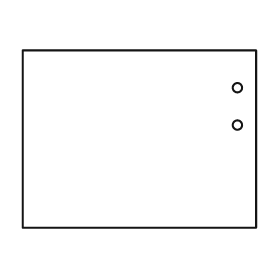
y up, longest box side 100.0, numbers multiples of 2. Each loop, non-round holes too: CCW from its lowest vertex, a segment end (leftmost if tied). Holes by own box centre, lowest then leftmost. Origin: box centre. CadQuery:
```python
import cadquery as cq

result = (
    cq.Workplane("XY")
    .moveTo(-50.0, -38.0)
    .lineTo(50.0, -38.0)
    .lineTo(50.0, 38.0)
    .lineTo(-50.0, 38.0)
    .close()
    .moveTo(42.0, 6.0)
    .circle(2.0)
    .moveTo(42.0, 22.0)
    .circle(2.0)
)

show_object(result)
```